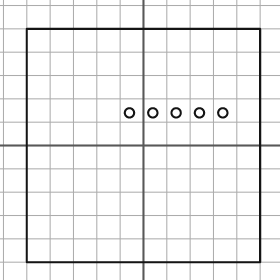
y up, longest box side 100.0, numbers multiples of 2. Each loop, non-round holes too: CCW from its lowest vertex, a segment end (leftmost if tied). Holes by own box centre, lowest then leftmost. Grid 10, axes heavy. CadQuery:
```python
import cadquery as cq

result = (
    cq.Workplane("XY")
    .moveTo(-50.0, -50.0)
    .lineTo(50.0, -50.0)
    .lineTo(50.0, 50.0)
    .lineTo(-50.0, 50.0)
    .close()
    .moveTo(-6.0, 14.0)
    .circle(2.0)
    .moveTo(4.0, 14.0)
    .circle(2.0)
    .moveTo(14.0, 14.0)
    .circle(2.0)
    .moveTo(24.0, 14.0)
    .circle(2.0)
    .moveTo(34.0, 14.0)
    .circle(2.0)
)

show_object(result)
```